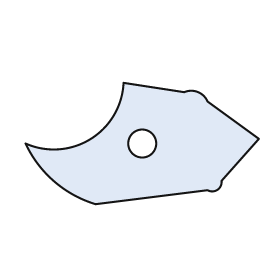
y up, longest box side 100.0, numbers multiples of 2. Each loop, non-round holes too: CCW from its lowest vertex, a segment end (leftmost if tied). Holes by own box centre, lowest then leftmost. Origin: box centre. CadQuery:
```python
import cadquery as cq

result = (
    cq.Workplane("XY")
    .moveTo(-20.0, -26.0)
    .lineTo(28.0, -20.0)
    .threePointArc((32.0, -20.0), (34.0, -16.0))
    .lineTo(50.0, 2.0)
    .lineTo(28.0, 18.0)
    .threePointArc((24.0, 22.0), (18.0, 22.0))
    .lineTo(-8.0, 26.0)
    .threePointArc((-22.0, 2.0), (-50.0, 0.0))
    .threePointArc((-38.0, -16.0), (-20.0, -26.0))
    .close()
    .moveTo(0.0, 0.0)
    .circle(6.0)
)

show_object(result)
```